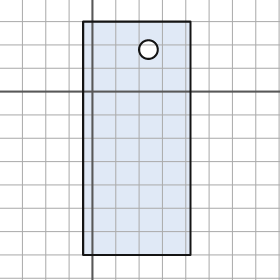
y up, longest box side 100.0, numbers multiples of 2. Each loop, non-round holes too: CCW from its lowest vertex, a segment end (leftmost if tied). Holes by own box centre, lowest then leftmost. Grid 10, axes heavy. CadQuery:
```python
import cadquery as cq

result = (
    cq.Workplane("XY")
    .moveTo(-4.0, -70.0)
    .lineTo(42.0, -70.0)
    .lineTo(42.0, 30.0)
    .lineTo(-4.0, 30.0)
    .close()
    .moveTo(24.0, 18.0)
    .circle(4.0)
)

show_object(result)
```